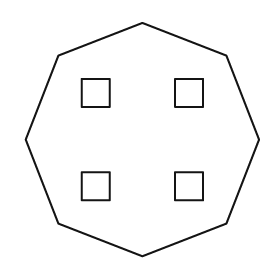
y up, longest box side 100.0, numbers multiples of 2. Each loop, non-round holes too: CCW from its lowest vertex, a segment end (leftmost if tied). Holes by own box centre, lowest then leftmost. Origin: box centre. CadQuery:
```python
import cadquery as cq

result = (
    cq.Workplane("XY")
    .moveTo(0.0, -50.0)
    .lineTo(36.0, -36.0)
    .lineTo(50.0, 0.0)
    .lineTo(36.0, 36.0)
    .lineTo(0.0, 50.0)
    .lineTo(-36.0, 36.0)
    .lineTo(-50.0, 0.0)
    .lineTo(-36.0, -36.0)
    .close()
    .moveTo(-26.0, -26.0)
    .lineTo(-14.0, -26.0)
    .lineTo(-14.0, -14.0)
    .lineTo(-26.0, -14.0)
    .close()
    .moveTo(14.0, -26.0)
    .lineTo(26.0, -26.0)
    .lineTo(26.0, -14.0)
    .lineTo(14.0, -14.0)
    .close()
    .moveTo(-26.0, 14.0)
    .lineTo(-14.0, 14.0)
    .lineTo(-14.0, 26.0)
    .lineTo(-26.0, 26.0)
    .close()
    .moveTo(14.0, 14.0)
    .lineTo(26.0, 14.0)
    .lineTo(26.0, 26.0)
    .lineTo(14.0, 26.0)
    .close()
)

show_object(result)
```